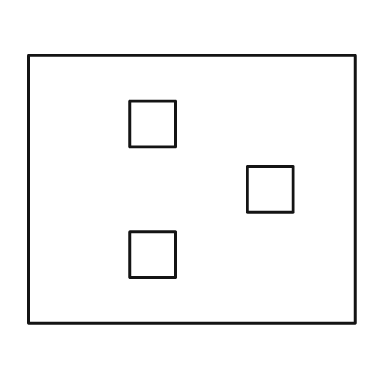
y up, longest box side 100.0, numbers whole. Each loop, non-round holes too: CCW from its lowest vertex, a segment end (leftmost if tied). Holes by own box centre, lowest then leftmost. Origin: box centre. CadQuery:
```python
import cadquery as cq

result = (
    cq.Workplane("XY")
    .moveTo(-50.0, -41.0)
    .lineTo(50.0, -41.0)
    .lineTo(50.0, 41.0)
    .lineTo(-50.0, 41.0)
    .close()
    .moveTo(-19.0, -27.0)
    .lineTo(-5.0, -27.0)
    .lineTo(-5.0, -13.0)
    .lineTo(-19.0, -13.0)
    .close()
    .moveTo(17.0, -7.0)
    .lineTo(31.0, -7.0)
    .lineTo(31.0, 7.0)
    .lineTo(17.0, 7.0)
    .close()
    .moveTo(-19.0, 13.0)
    .lineTo(-5.0, 13.0)
    .lineTo(-5.0, 27.0)
    .lineTo(-19.0, 27.0)
    .close()
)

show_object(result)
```